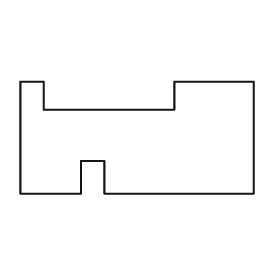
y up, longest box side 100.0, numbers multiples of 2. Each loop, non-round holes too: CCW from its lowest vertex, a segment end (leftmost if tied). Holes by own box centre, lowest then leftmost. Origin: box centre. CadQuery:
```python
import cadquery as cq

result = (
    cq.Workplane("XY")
    .moveTo(-50.0, -24.0)
    .lineTo(-24.0, -24.0)
    .lineTo(-24.0, -10.0)
    .lineTo(-14.0, -10.0)
    .lineTo(-14.0, -24.0)
    .lineTo(50.0, -24.0)
    .lineTo(50.0, 24.0)
    .lineTo(16.0, 24.0)
    .lineTo(16.0, 12.0)
    .lineTo(-40.0, 12.0)
    .lineTo(-40.0, 24.0)
    .lineTo(-50.0, 24.0)
    .close()
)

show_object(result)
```